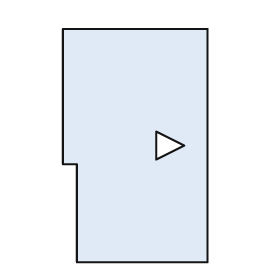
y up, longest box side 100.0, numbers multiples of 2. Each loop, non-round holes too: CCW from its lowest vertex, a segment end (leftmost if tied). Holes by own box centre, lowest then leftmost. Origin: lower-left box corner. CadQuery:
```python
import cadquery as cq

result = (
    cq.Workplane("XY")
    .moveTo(6.0, 0.0)
    .lineTo(62.0, 0.0)
    .lineTo(62.0, 100.0)
    .lineTo(0.0, 100.0)
    .lineTo(0.0, 42.0)
    .lineTo(6.0, 42.0)
    .close()
    .moveTo(40.0, 44.0)
    .lineTo(52.0, 50.0)
    .lineTo(40.0, 56.0)
    .close()
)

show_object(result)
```